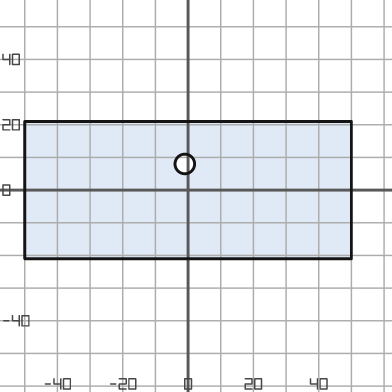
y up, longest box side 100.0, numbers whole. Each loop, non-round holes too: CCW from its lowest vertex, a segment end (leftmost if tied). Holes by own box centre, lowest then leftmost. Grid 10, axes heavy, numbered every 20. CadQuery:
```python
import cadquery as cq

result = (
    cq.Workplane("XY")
    .moveTo(-50.0, -21.0)
    .lineTo(50.0, -21.0)
    .lineTo(50.0, 21.0)
    .lineTo(-50.0, 21.0)
    .close()
    .moveTo(-1.0, 8.0)
    .circle(3.0)
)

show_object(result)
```